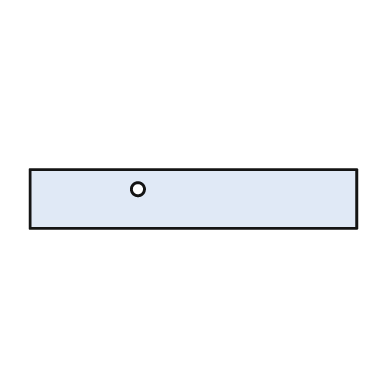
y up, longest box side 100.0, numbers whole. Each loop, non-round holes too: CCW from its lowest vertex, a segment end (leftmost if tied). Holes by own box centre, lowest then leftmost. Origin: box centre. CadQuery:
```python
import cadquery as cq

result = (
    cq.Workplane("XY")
    .moveTo(-50.0, -9.0)
    .lineTo(50.0, -9.0)
    .lineTo(50.0, 9.0)
    .lineTo(-50.0, 9.0)
    .close()
    .moveTo(-17.0, 3.0)
    .circle(2.0)
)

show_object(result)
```